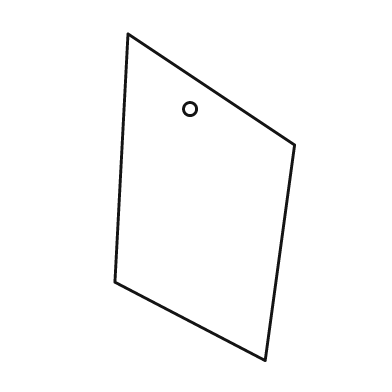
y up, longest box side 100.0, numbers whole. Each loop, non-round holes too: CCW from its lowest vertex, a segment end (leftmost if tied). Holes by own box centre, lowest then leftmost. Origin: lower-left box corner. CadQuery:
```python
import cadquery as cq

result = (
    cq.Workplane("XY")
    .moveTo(46.0, 0.0)
    .lineTo(55.0, 66.0)
    .lineTo(4.0, 100.0)
    .lineTo(0.0, 24.0)
    .close()
    .moveTo(23.0, 77.0)
    .circle(2.0)
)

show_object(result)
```